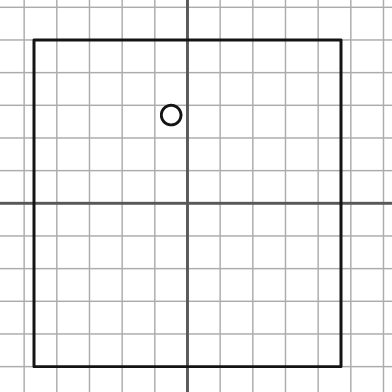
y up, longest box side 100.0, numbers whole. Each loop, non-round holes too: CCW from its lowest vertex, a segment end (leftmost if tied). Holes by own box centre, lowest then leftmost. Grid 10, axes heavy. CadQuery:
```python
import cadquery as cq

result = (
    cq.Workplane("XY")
    .moveTo(-47.0, -50.0)
    .lineTo(47.0, -50.0)
    .lineTo(47.0, 50.0)
    .lineTo(-47.0, 50.0)
    .close()
    .moveTo(-5.0, 27.0)
    .circle(3.0)
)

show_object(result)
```